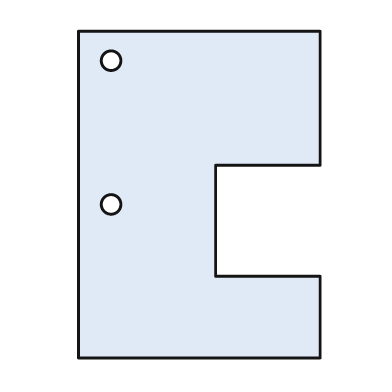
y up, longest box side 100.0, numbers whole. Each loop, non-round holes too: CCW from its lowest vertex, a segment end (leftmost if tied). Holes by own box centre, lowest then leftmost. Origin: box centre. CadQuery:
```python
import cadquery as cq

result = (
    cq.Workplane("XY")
    .moveTo(-37.0, -50.0)
    .lineTo(37.0, -50.0)
    .lineTo(37.0, -25.0)
    .lineTo(5.0, -25.0)
    .lineTo(5.0, 9.0)
    .lineTo(37.0, 9.0)
    .lineTo(37.0, 50.0)
    .lineTo(-37.0, 50.0)
    .close()
    .moveTo(-27.0, -3.0)
    .circle(3.0)
    .moveTo(-27.0, 41.0)
    .circle(3.0)
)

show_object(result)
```